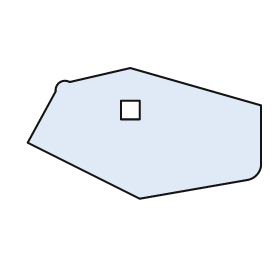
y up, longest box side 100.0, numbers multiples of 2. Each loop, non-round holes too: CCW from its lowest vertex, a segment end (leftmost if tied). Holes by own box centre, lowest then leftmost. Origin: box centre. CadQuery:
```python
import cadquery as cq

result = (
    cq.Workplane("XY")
    .moveTo(-2.0, -28.0)
    .lineTo(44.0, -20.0)
    .threePointArc((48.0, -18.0), (50.0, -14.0))
    .lineTo(50.0, 12.0)
    .lineTo(-6.0, 28.0)
    .lineTo(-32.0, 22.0)
    .threePointArc((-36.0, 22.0), (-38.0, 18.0))
    .lineTo(-50.0, -4.0)
    .close()
    .moveTo(-10.0, 6.0)
    .lineTo(-2.0, 6.0)
    .lineTo(-2.0, 14.0)
    .lineTo(-10.0, 14.0)
    .close()
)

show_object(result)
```